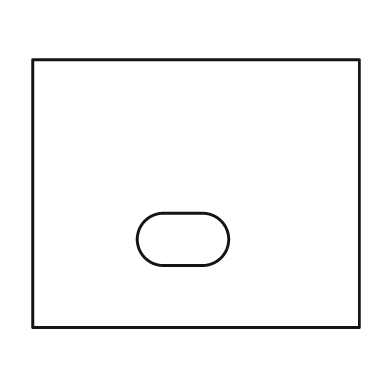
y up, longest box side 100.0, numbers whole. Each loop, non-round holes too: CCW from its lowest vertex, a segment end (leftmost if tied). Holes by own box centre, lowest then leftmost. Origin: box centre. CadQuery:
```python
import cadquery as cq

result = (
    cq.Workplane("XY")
    .moveTo(-50.0, -41.0)
    .lineTo(50.0, -41.0)
    .lineTo(50.0, 41.0)
    .lineTo(-50.0, 41.0)
    .close()
    .moveTo(-10.0, -22.0)
    .lineTo(2.0, -22.0)
    .threePointArc((10.0, -14.0), (2.0, -6.0))
    .lineTo(-10.0, -6.0)
    .threePointArc((-18.0, -14.0), (-10.0, -22.0))
    .close()
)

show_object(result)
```